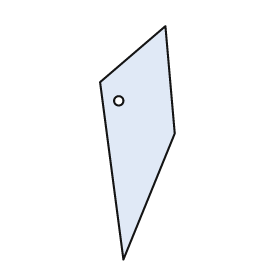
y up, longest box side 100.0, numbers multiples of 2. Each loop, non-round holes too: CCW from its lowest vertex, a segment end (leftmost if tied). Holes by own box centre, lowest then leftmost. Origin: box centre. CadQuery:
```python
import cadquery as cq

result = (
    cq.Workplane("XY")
    .moveTo(-6.0, -50.0)
    .lineTo(16.0, 4.0)
    .lineTo(12.0, 50.0)
    .lineTo(-16.0, 26.0)
    .close()
    .moveTo(-8.0, 18.0)
    .circle(2.0)
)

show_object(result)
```